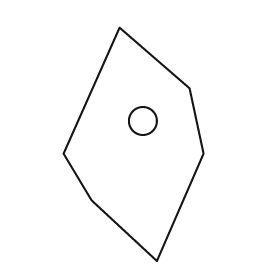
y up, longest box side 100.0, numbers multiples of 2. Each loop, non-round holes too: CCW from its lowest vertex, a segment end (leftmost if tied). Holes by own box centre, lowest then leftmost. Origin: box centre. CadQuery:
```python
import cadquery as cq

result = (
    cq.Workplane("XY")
    .moveTo(10.0, -50.0)
    .lineTo(30.0, -4.0)
    .lineTo(24.0, 24.0)
    .lineTo(-6.0, 50.0)
    .lineTo(-30.0, -4.0)
    .lineTo(-18.0, -24.0)
    .close()
    .moveTo(4.0, 10.0)
    .circle(6.0)
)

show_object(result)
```